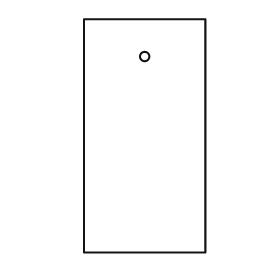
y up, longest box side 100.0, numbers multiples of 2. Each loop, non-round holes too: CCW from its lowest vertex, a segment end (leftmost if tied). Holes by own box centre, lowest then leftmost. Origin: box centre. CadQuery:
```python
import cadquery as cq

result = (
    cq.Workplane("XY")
    .moveTo(-26.0, -50.0)
    .lineTo(26.0, -50.0)
    .lineTo(26.0, 50.0)
    .lineTo(-26.0, 50.0)
    .close()
    .moveTo(0.0, 34.0)
    .circle(2.0)
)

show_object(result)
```